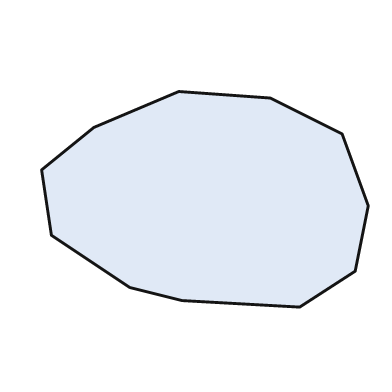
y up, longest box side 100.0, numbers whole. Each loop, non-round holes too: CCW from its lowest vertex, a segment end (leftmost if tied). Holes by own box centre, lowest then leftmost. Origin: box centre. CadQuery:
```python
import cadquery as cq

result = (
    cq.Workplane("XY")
    .moveTo(29.0, -33.0)
    .lineTo(46.0, -22.0)
    .lineTo(50.0, -2.0)
    .lineTo(42.0, 20.0)
    .lineTo(20.0, 31.0)
    .lineTo(-8.0, 33.0)
    .lineTo(-34.0, 22.0)
    .lineTo(-50.0, 9.0)
    .lineTo(-47.0, -11.0)
    .lineTo(-23.0, -27.0)
    .lineTo(-7.0, -31.0)
    .close()
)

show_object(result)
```